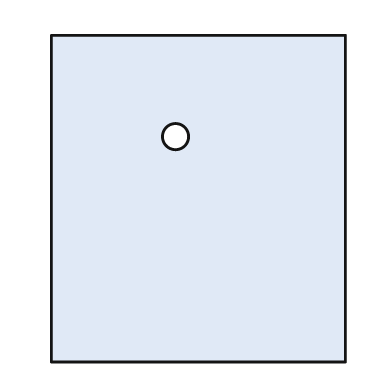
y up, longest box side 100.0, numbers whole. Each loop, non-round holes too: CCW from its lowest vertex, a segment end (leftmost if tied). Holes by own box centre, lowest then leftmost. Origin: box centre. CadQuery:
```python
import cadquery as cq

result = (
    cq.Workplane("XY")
    .moveTo(-45.0, -50.0)
    .lineTo(45.0, -50.0)
    .lineTo(45.0, 50.0)
    .lineTo(-45.0, 50.0)
    .close()
    .moveTo(-7.0, 19.0)
    .circle(4.0)
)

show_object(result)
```